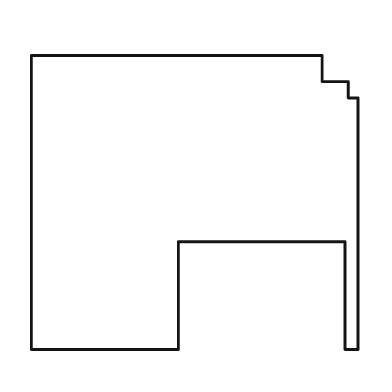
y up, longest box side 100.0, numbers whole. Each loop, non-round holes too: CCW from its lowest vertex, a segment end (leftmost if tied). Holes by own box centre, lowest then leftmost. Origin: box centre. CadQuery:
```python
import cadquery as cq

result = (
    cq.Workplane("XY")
    .moveTo(-50.0, -45.0)
    .lineTo(-5.0, -45.0)
    .lineTo(-5.0, -12.0)
    .lineTo(46.0, -12.0)
    .lineTo(46.0, -45.0)
    .lineTo(50.0, -45.0)
    .lineTo(50.0, 32.0)
    .lineTo(47.0, 32.0)
    .lineTo(47.0, 37.0)
    .lineTo(39.0, 37.0)
    .lineTo(39.0, 45.0)
    .lineTo(-50.0, 45.0)
    .close()
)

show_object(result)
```